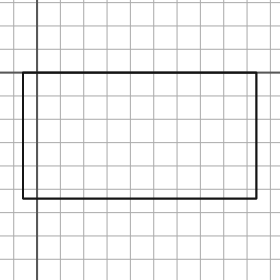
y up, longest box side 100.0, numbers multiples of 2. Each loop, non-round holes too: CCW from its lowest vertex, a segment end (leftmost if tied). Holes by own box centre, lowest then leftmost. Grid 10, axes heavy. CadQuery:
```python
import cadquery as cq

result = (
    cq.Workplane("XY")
    .moveTo(-6.0, -54.0)
    .lineTo(94.0, -54.0)
    .lineTo(94.0, 0.0)
    .lineTo(-6.0, 0.0)
    .close()
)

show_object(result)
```